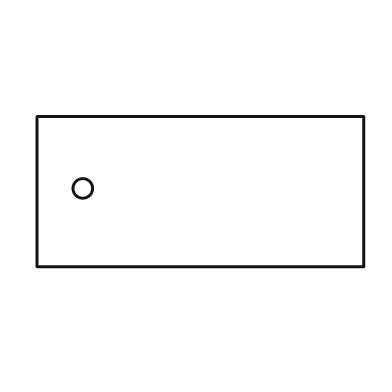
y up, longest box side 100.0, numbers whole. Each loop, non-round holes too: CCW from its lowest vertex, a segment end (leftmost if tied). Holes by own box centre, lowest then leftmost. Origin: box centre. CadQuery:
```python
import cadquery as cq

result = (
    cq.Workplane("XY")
    .moveTo(-50.0, -23.0)
    .lineTo(50.0, -23.0)
    .lineTo(50.0, 23.0)
    .lineTo(-50.0, 23.0)
    .close()
    .moveTo(-36.0, 1.0)
    .circle(3.0)
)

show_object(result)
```